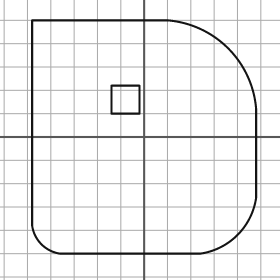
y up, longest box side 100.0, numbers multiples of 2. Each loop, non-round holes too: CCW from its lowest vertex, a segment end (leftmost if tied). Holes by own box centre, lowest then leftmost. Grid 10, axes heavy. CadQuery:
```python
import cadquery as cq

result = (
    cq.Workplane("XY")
    .moveTo(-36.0, -50.0)
    .lineTo(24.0, -50.0)
    .threePointArc((40.0, -42.0), (48.0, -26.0))
    .lineTo(48.0, 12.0)
    .threePointArc((36.0, 38.0), (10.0, 50.0))
    .lineTo(-48.0, 50.0)
    .lineTo(-48.0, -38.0)
    .threePointArc((-44.0, -46.0), (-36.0, -50.0))
    .close()
    .moveTo(-14.0, 10.0)
    .lineTo(-2.0, 10.0)
    .lineTo(-2.0, 22.0)
    .lineTo(-14.0, 22.0)
    .close()
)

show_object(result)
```